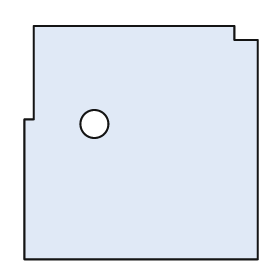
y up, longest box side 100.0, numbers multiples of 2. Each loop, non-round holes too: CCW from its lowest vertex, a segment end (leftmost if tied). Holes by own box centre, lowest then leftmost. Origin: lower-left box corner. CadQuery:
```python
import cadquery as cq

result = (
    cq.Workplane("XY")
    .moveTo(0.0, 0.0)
    .lineTo(100.0, 0.0)
    .lineTo(100.0, 94.0)
    .lineTo(90.0, 94.0)
    .lineTo(90.0, 100.0)
    .lineTo(4.0, 100.0)
    .lineTo(4.0, 60.0)
    .lineTo(0.0, 60.0)
    .close()
    .moveTo(30.0, 58.0)
    .circle(6.0)
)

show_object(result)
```